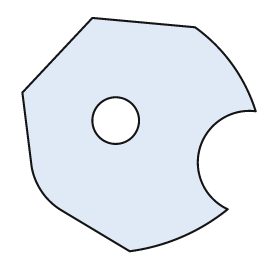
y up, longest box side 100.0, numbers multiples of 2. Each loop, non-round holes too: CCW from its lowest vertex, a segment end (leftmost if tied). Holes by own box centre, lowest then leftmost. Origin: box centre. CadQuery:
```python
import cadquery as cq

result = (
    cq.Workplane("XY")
    .moveTo(-4.0, -50.0)
    .threePointArc((18.0, -44.0), (38.0, -32.0))
    .threePointArc((26.0, -6.0), (50.0, 10.0))
    .threePointArc((40.0, 30.0), (24.0, 46.0))
    .lineTo(-20.0, 50.0)
    .lineTo(-50.0, 18.0)
    .lineTo(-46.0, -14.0)
    .threePointArc((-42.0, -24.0), (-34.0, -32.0))
    .close()
    .moveTo(-10.0, 6.0)
    .circle(10.0)
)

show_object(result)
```